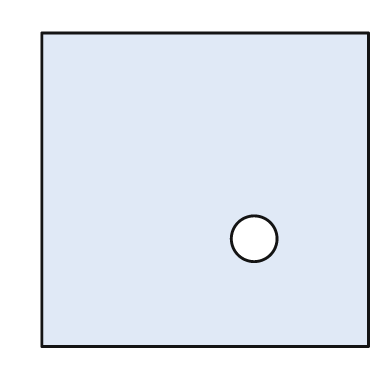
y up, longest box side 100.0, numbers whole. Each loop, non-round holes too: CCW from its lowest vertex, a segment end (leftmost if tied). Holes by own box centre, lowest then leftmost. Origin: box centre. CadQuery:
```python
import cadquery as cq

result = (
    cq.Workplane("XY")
    .moveTo(-50.0, -48.0)
    .lineTo(50.0, -48.0)
    .lineTo(50.0, 48.0)
    .lineTo(-50.0, 48.0)
    .close()
    .moveTo(15.0, -15.0)
    .circle(7.0)
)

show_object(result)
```